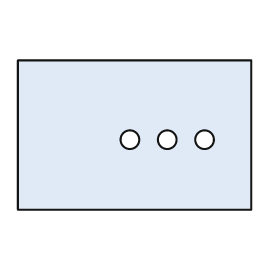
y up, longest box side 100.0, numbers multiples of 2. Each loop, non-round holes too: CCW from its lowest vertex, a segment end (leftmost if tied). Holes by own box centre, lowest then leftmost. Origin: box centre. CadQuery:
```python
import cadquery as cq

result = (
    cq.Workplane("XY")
    .moveTo(-50.0, -32.0)
    .lineTo(50.0, -32.0)
    .lineTo(50.0, 32.0)
    .lineTo(-50.0, 32.0)
    .close()
    .moveTo(-2.0, -2.0)
    .circle(4.0)
    .moveTo(14.0, -2.0)
    .circle(4.0)
    .moveTo(30.0, -2.0)
    .circle(4.0)
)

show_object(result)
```